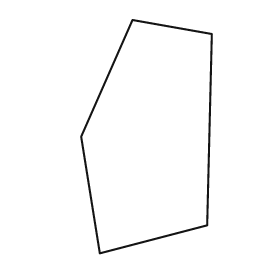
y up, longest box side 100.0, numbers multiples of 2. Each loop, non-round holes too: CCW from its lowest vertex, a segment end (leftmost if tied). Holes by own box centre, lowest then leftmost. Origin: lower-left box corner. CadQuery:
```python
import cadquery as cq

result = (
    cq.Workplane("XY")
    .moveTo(8.0, 0.0)
    .lineTo(54.0, 12.0)
    .lineTo(56.0, 94.0)
    .lineTo(22.0, 100.0)
    .lineTo(0.0, 50.0)
    .close()
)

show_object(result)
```